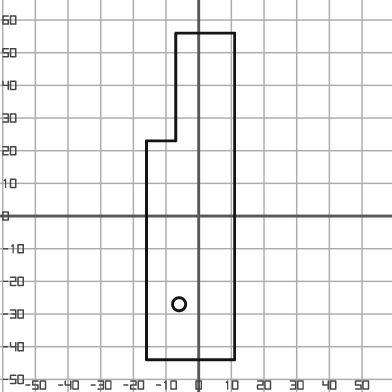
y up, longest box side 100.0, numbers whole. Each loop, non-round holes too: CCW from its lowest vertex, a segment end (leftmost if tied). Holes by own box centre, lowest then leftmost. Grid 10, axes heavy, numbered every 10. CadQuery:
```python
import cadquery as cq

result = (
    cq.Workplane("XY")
    .moveTo(-16.0, -44.0)
    .lineTo(11.0, -44.0)
    .lineTo(11.0, 56.0)
    .lineTo(-7.0, 56.0)
    .lineTo(-7.0, 23.0)
    .lineTo(-16.0, 23.0)
    .close()
    .moveTo(-6.0, -27.0)
    .circle(2.0)
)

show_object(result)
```